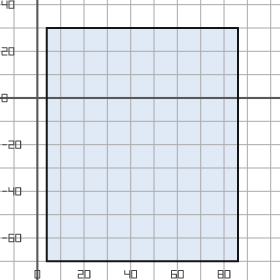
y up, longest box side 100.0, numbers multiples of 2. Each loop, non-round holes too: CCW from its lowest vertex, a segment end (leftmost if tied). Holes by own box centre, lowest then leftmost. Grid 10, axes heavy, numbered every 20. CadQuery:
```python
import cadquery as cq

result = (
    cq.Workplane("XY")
    .moveTo(4.0, -70.0)
    .lineTo(86.0, -70.0)
    .lineTo(86.0, 30.0)
    .lineTo(4.0, 30.0)
    .close()
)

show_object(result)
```